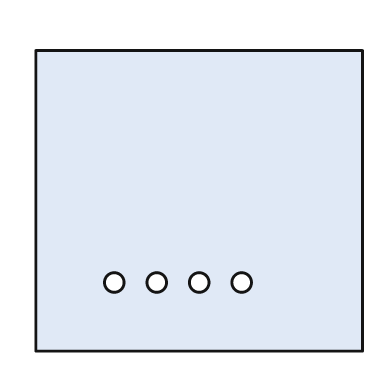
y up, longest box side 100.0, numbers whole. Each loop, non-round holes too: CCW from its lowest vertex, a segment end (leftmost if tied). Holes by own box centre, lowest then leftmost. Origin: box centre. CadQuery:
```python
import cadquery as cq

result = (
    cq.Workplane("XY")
    .moveTo(-50.0, -46.0)
    .lineTo(50.0, -46.0)
    .lineTo(50.0, 46.0)
    .lineTo(-50.0, 46.0)
    .close()
    .moveTo(-26.0, -25.0)
    .circle(3.0)
    .moveTo(-13.0, -25.0)
    .circle(3.0)
    .moveTo(0.0, -25.0)
    .circle(3.0)
    .moveTo(13.0, -25.0)
    .circle(3.0)
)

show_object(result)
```